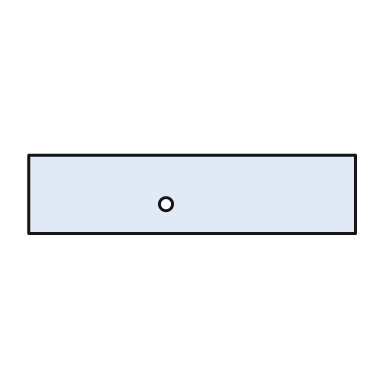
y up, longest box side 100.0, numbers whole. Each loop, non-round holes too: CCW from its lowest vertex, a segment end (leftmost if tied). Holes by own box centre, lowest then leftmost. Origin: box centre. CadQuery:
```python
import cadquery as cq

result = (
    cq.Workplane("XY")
    .moveTo(-50.0, -12.0)
    .lineTo(50.0, -12.0)
    .lineTo(50.0, 12.0)
    .lineTo(-50.0, 12.0)
    .close()
    .moveTo(-8.0, -3.0)
    .circle(2.0)
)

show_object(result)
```